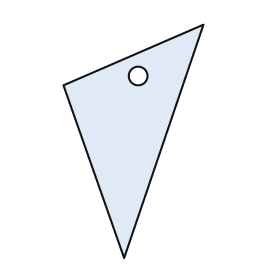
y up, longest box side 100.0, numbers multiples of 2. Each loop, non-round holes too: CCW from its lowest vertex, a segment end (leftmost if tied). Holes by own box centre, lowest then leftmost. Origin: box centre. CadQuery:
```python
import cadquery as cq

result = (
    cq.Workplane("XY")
    .moveTo(-4.0, -50.0)
    .lineTo(30.0, 50.0)
    .lineTo(-30.0, 24.0)
    .close()
    .moveTo(2.0, 28.0)
    .circle(4.0)
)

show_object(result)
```